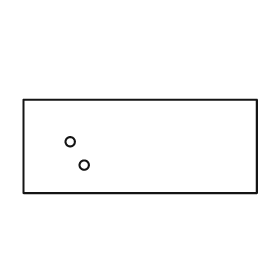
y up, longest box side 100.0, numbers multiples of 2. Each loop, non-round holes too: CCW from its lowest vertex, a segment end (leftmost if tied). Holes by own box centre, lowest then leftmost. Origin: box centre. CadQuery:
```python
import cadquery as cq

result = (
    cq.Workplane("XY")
    .moveTo(-50.0, -20.0)
    .lineTo(50.0, -20.0)
    .lineTo(50.0, 20.0)
    .lineTo(-50.0, 20.0)
    .close()
    .moveTo(-24.0, -8.0)
    .circle(2.0)
    .moveTo(-30.0, 2.0)
    .circle(2.0)
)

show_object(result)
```